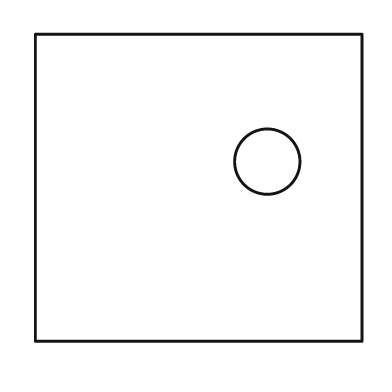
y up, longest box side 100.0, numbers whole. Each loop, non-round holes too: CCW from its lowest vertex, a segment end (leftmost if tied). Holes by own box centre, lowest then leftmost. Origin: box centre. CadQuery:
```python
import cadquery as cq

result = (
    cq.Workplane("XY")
    .moveTo(-50.0, -47.0)
    .lineTo(50.0, -47.0)
    .lineTo(50.0, 47.0)
    .lineTo(-50.0, 47.0)
    .close()
    .moveTo(21.0, 8.0)
    .circle(10.0)
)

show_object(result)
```